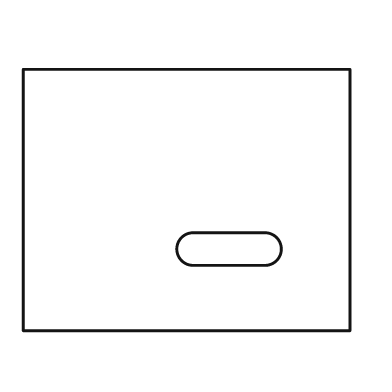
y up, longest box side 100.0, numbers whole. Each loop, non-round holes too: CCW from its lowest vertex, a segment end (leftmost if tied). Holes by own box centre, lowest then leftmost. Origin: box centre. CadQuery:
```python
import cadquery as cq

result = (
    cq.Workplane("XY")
    .moveTo(-50.0, -40.0)
    .lineTo(50.0, -40.0)
    .lineTo(50.0, 40.0)
    .lineTo(-50.0, 40.0)
    .close()
    .moveTo(2.0, -20.0)
    .lineTo(24.0, -20.0)
    .threePointArc((29.0, -15.0), (24.0, -10.0))
    .lineTo(2.0, -10.0)
    .threePointArc((-3.0, -15.0), (2.0, -20.0))
    .close()
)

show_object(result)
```